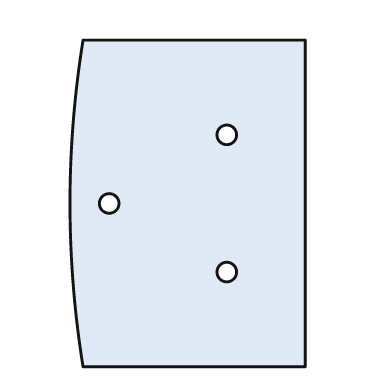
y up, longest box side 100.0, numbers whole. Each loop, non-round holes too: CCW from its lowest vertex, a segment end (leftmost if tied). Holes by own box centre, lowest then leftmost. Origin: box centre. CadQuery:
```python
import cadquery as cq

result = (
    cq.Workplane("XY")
    .moveTo(-32.0, -50.0)
    .lineTo(36.0, -50.0)
    .lineTo(36.0, 50.0)
    .lineTo(-32.0, 50.0)
    .threePointArc((-36.0, 0.0), (-32.0, -50.0))
    .close()
    .moveTo(12.0, -21.0)
    .circle(3.0)
    .moveTo(-24.0, 0.0)
    .circle(3.0)
    .moveTo(12.0, 21.0)
    .circle(3.0)
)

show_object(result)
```